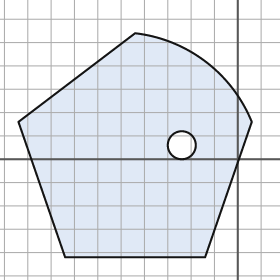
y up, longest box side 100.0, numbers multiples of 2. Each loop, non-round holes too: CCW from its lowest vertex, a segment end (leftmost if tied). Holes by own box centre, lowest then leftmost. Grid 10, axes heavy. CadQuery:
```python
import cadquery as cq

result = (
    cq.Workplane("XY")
    .moveTo(-74.0, -42.0)
    .lineTo(-14.0, -42.0)
    .lineTo(6.0, 16.0)
    .threePointArc((-14.0, 42.0), (-44.0, 54.0))
    .lineTo(-94.0, 16.0)
    .close()
    .moveTo(-24.0, 6.0)
    .circle(6.0)
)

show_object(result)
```